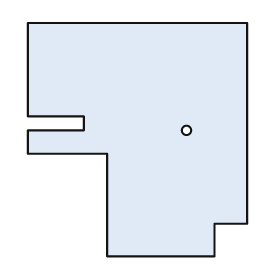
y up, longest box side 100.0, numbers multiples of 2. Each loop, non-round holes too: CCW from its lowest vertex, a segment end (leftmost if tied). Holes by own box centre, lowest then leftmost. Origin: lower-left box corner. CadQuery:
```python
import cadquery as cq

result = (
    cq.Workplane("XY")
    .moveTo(34.0, 0.0)
    .lineTo(80.0, 0.0)
    .lineTo(80.0, 14.0)
    .lineTo(94.0, 14.0)
    .lineTo(94.0, 100.0)
    .lineTo(0.0, 100.0)
    .lineTo(0.0, 60.0)
    .lineTo(24.0, 60.0)
    .lineTo(24.0, 54.0)
    .lineTo(0.0, 54.0)
    .lineTo(0.0, 44.0)
    .lineTo(34.0, 44.0)
    .close()
    .moveTo(68.0, 54.0)
    .circle(2.0)
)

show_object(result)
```